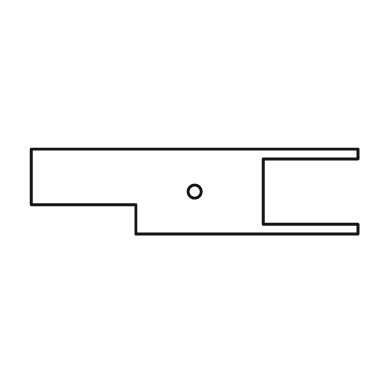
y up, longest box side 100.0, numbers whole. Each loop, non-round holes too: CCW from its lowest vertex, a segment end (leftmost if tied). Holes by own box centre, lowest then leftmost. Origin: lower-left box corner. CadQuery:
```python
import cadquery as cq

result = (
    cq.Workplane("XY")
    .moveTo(32.0, 0.0)
    .lineTo(100.0, 0.0)
    .lineTo(100.0, 3.0)
    .lineTo(71.0, 3.0)
    .lineTo(71.0, 23.0)
    .lineTo(100.0, 23.0)
    .lineTo(100.0, 26.0)
    .lineTo(0.0, 26.0)
    .lineTo(0.0, 9.0)
    .lineTo(32.0, 9.0)
    .close()
    .moveTo(50.0, 13.0)
    .circle(2.0)
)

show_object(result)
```